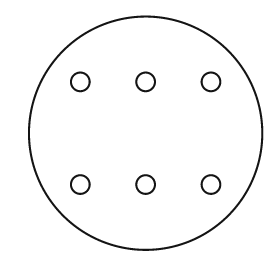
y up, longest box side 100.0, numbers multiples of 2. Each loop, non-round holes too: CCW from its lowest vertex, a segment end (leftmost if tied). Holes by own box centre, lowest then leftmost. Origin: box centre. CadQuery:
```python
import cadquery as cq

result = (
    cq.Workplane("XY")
    .moveTo(0.0, 0.0)
    .circle(50.0)
    .moveTo(-28.0, -22.0)
    .circle(4.0)
    .moveTo(0.0, -22.0)
    .circle(4.0)
    .moveTo(28.0, -22.0)
    .circle(4.0)
    .moveTo(-28.0, 22.0)
    .circle(4.0)
    .moveTo(0.0, 22.0)
    .circle(4.0)
    .moveTo(28.0, 22.0)
    .circle(4.0)
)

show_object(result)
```